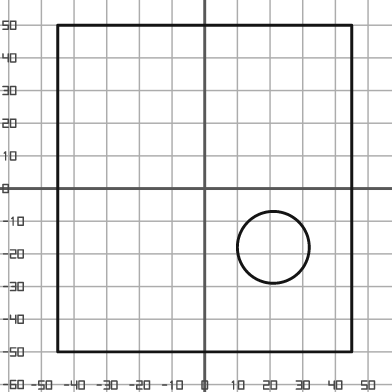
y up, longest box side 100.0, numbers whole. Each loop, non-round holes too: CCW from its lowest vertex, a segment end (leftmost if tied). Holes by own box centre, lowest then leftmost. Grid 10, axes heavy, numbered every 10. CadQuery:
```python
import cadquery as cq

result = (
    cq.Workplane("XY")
    .moveTo(-45.0, -50.0)
    .lineTo(45.0, -50.0)
    .lineTo(45.0, 50.0)
    .lineTo(-45.0, 50.0)
    .close()
    .moveTo(21.0, -18.0)
    .circle(11.0)
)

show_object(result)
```